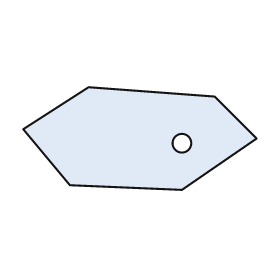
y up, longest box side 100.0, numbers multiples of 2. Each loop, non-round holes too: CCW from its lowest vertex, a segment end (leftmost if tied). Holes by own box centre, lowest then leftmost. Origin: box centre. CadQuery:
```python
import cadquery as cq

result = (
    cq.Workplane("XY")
    .moveTo(18.0, -22.0)
    .lineTo(50.0, 0.0)
    .lineTo(32.0, 18.0)
    .lineTo(-22.0, 22.0)
    .lineTo(-50.0, 4.0)
    .lineTo(-30.0, -20.0)
    .close()
    .moveTo(18.0, -2.0)
    .circle(4.0)
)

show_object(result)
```